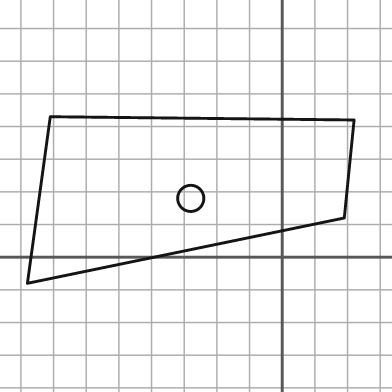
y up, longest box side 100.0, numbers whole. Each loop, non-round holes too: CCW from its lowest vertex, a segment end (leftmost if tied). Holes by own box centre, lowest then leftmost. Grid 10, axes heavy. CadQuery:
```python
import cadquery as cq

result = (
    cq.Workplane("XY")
    .moveTo(-78.0, -8.0)
    .lineTo(19.0, 12.0)
    .lineTo(22.0, 42.0)
    .lineTo(-71.0, 43.0)
    .close()
    .moveTo(-28.0, 18.0)
    .circle(4.0)
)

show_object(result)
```